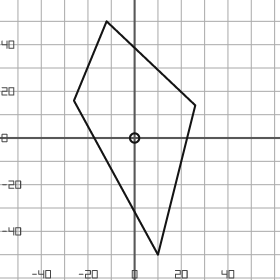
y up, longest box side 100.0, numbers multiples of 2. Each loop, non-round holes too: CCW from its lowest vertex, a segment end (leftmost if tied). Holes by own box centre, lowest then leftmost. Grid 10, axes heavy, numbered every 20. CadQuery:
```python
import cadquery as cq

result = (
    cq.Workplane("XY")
    .moveTo(10.0, -50.0)
    .lineTo(26.0, 14.0)
    .lineTo(-12.0, 50.0)
    .lineTo(-26.0, 16.0)
    .close()
    .moveTo(0.0, 0.0)
    .circle(2.0)
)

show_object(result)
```